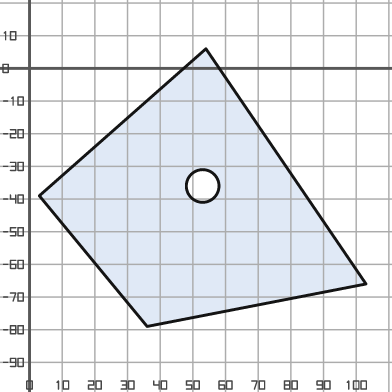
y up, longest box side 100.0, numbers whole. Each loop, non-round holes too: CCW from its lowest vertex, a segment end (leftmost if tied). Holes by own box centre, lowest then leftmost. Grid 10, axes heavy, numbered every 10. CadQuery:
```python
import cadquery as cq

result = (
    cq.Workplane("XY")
    .moveTo(36.0, -79.0)
    .lineTo(103.0, -66.0)
    .lineTo(54.0, 6.0)
    .lineTo(3.0, -39.0)
    .close()
    .moveTo(53.0, -36.0)
    .circle(5.0)
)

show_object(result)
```